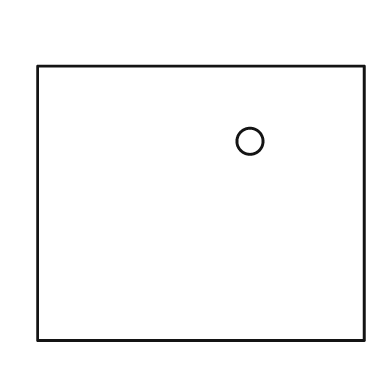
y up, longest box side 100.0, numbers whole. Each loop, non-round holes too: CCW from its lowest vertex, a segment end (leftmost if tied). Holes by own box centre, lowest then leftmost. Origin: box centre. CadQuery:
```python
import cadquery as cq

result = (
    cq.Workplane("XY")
    .moveTo(-50.0, -42.0)
    .lineTo(50.0, -42.0)
    .lineTo(50.0, 42.0)
    .lineTo(-50.0, 42.0)
    .close()
    .moveTo(15.0, 19.0)
    .circle(4.0)
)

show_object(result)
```